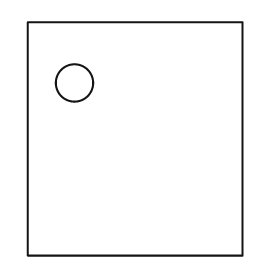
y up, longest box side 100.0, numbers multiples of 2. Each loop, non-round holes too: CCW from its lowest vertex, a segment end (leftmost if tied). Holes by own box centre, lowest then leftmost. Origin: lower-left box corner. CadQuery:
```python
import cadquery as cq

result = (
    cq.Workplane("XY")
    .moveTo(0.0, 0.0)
    .lineTo(92.0, 0.0)
    .lineTo(92.0, 100.0)
    .lineTo(0.0, 100.0)
    .close()
    .moveTo(20.0, 74.0)
    .circle(8.0)
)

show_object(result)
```